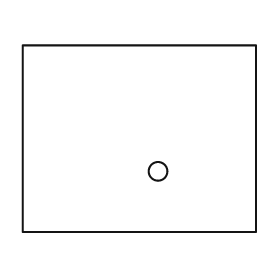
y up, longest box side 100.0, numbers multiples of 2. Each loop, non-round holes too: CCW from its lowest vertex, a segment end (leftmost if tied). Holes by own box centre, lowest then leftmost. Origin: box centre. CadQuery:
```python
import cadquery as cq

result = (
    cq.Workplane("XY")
    .moveTo(-50.0, -40.0)
    .lineTo(50.0, -40.0)
    .lineTo(50.0, 40.0)
    .lineTo(-50.0, 40.0)
    .close()
    .moveTo(8.0, -14.0)
    .circle(4.0)
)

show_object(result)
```